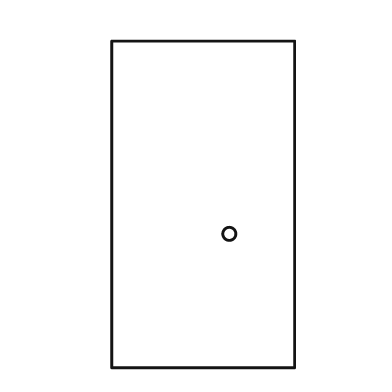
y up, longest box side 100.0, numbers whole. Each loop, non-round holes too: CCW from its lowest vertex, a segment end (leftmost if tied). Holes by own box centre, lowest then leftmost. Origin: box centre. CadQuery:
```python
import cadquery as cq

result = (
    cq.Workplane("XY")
    .moveTo(-28.0, -50.0)
    .lineTo(28.0, -50.0)
    .lineTo(28.0, 50.0)
    .lineTo(-28.0, 50.0)
    .close()
    .moveTo(8.0, -9.0)
    .circle(2.0)
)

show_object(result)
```